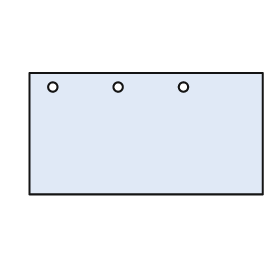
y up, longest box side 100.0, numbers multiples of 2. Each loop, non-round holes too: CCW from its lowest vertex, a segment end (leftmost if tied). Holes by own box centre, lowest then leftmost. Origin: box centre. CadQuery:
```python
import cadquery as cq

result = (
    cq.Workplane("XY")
    .moveTo(-50.0, -26.0)
    .lineTo(50.0, -26.0)
    .lineTo(50.0, 26.0)
    .lineTo(-50.0, 26.0)
    .close()
    .moveTo(-40.0, 20.0)
    .circle(2.0)
    .moveTo(-12.0, 20.0)
    .circle(2.0)
    .moveTo(16.0, 20.0)
    .circle(2.0)
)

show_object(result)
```